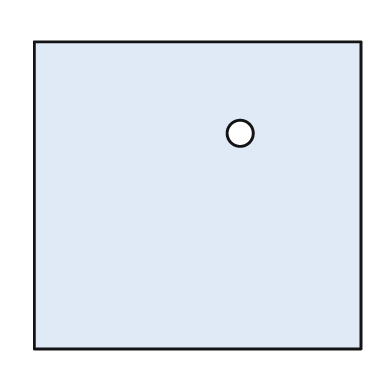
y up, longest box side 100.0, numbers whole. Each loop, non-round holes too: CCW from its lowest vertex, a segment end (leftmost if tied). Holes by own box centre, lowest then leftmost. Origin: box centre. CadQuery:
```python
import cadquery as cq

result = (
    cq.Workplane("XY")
    .moveTo(-50.0, -47.0)
    .lineTo(50.0, -47.0)
    .lineTo(50.0, 47.0)
    .lineTo(-50.0, 47.0)
    .close()
    .moveTo(13.0, 19.0)
    .circle(4.0)
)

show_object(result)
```